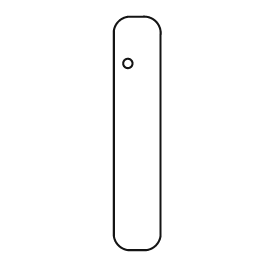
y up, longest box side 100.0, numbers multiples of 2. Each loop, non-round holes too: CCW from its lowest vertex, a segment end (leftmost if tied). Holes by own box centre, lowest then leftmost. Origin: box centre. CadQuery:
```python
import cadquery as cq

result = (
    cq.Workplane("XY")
    .moveTo(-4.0, -50.0)
    .lineTo(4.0, -50.0)
    .threePointArc((8.0, -48.0), (10.0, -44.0))
    .lineTo(10.0, 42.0)
    .threePointArc((8.0, 48.0), (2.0, 50.0))
    .lineTo(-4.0, 50.0)
    .threePointArc((-8.0, 48.0), (-10.0, 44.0))
    .lineTo(-10.0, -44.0)
    .threePointArc((-8.0, -48.0), (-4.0, -50.0))
    .close()
    .moveTo(-4.0, 30.0)
    .circle(2.0)
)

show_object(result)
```